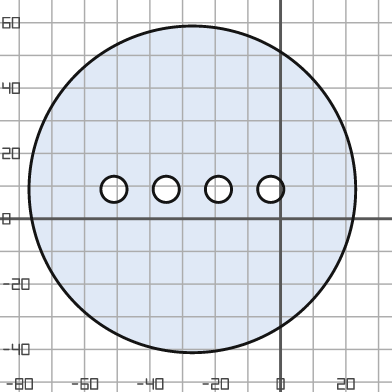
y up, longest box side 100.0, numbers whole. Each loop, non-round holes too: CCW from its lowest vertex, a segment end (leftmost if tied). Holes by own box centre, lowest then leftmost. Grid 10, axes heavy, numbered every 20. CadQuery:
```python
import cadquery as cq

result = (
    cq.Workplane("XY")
    .moveTo(-27.0, 9.0)
    .circle(50.0)
    .moveTo(-51.0, 9.0)
    .circle(4.0)
    .moveTo(-35.0, 9.0)
    .circle(4.0)
    .moveTo(-19.0, 9.0)
    .circle(4.0)
    .moveTo(-3.0, 9.0)
    .circle(4.0)
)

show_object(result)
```